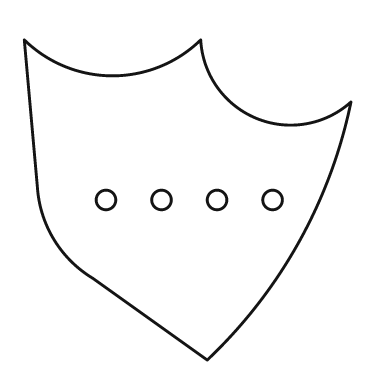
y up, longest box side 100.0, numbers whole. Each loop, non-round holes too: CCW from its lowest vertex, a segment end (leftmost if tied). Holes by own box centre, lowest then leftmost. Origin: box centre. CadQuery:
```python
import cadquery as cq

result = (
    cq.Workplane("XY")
    .moveTo(6.0, -49.0)
    .threePointArc((34.0, -13.0), (50.0, 30.0))
    .threePointArc((21.0, 25.0), (4.0, 49.0))
    .threePointArc((-23.0, 38.0), (-50.0, 49.0))
    .lineTo(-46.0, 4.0)
    .threePointArc((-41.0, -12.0), (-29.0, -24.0))
    .close()
    .moveTo(-25.0, 0.0)
    .circle(3.0)
    .moveTo(-8.0, 0.0)
    .circle(3.0)
    .moveTo(9.0, 0.0)
    .circle(3.0)
    .moveTo(26.0, 0.0)
    .circle(3.0)
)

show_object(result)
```